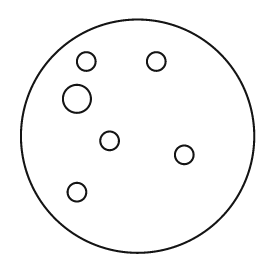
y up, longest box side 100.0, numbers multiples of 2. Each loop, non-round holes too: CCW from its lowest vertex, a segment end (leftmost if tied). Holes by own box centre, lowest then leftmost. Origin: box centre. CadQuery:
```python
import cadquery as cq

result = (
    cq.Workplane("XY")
    .moveTo(0.0, 0.0)
    .circle(50.0)
    .moveTo(-26.0, -24.0)
    .circle(4.0)
    .moveTo(20.0, -8.0)
    .circle(4.0)
    .moveTo(-12.0, -2.0)
    .circle(4.0)
    .moveTo(-26.0, 16.0)
    .circle(6.0)
    .moveTo(-22.0, 32.0)
    .circle(4.0)
    .moveTo(8.0, 32.0)
    .circle(4.0)
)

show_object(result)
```